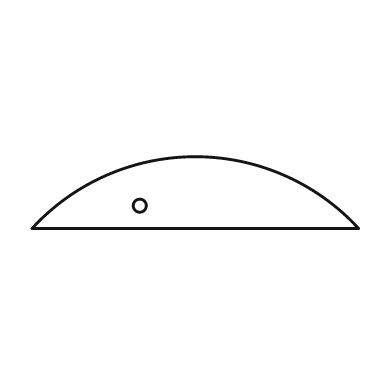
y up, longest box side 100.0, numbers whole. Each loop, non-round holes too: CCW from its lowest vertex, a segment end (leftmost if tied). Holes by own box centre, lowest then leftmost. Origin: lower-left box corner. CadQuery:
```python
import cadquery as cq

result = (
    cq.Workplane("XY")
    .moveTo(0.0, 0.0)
    .lineTo(100.0, 0.0)
    .threePointArc((50.0, 22.0), (0.0, 0.0))
    .close()
    .moveTo(33.0, 7.0)
    .circle(2.0)
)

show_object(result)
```